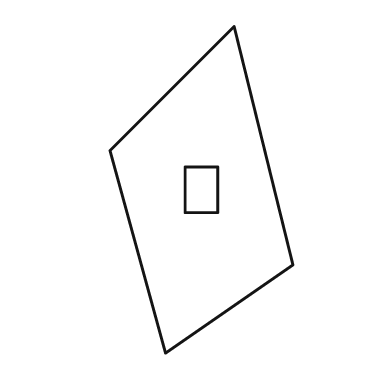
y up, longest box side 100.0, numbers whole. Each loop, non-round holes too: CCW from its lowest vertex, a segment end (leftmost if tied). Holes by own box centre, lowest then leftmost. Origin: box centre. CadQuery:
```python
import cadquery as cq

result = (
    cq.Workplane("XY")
    .moveTo(-11.0, -50.0)
    .lineTo(28.0, -23.0)
    .lineTo(10.0, 50.0)
    .lineTo(-28.0, 12.0)
    .close()
    .moveTo(-5.0, -7.0)
    .lineTo(5.0, -7.0)
    .lineTo(5.0, 7.0)
    .lineTo(-5.0, 7.0)
    .close()
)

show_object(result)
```